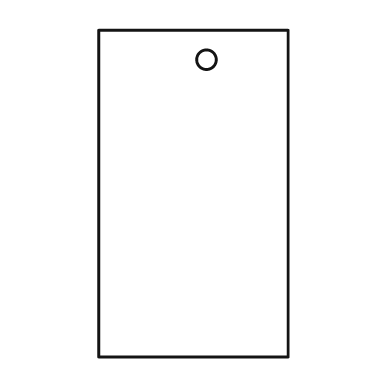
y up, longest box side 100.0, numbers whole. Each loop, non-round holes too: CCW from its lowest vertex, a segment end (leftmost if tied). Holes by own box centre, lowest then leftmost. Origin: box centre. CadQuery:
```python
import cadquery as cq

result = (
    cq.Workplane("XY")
    .moveTo(-29.0, -50.0)
    .lineTo(29.0, -50.0)
    .lineTo(29.0, 50.0)
    .lineTo(-29.0, 50.0)
    .close()
    .moveTo(4.0, 41.0)
    .circle(3.0)
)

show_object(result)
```